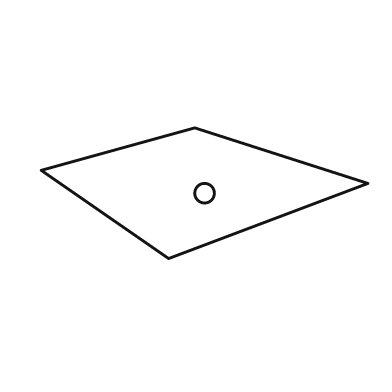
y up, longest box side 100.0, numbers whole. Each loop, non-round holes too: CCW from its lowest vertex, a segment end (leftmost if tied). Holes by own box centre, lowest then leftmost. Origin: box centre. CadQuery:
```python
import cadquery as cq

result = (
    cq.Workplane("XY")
    .moveTo(-11.0, -20.0)
    .lineTo(50.0, 3.0)
    .lineTo(-3.0, 20.0)
    .lineTo(-50.0, 7.0)
    .close()
    .moveTo(0.0, 0.0)
    .circle(3.0)
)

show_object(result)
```